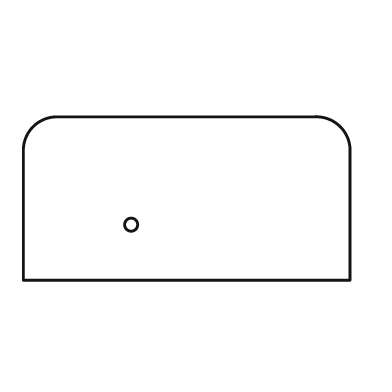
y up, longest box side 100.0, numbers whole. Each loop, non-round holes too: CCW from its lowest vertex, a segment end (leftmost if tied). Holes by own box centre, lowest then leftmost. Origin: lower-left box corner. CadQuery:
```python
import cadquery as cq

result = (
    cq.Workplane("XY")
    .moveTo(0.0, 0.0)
    .lineTo(100.0, 0.0)
    .lineTo(100.0, 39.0)
    .threePointArc((97.0, 47.0), (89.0, 50.0))
    .lineTo(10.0, 50.0)
    .threePointArc((3.0, 47.0), (0.0, 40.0))
    .close()
    .moveTo(33.0, 17.0)
    .circle(2.0)
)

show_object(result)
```